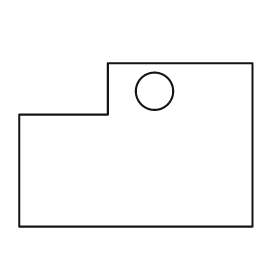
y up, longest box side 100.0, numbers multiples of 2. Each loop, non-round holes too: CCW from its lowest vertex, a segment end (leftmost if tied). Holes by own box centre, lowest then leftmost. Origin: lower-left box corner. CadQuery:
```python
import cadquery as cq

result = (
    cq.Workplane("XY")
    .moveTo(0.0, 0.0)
    .lineTo(100.0, 0.0)
    .lineTo(100.0, 70.0)
    .lineTo(38.0, 70.0)
    .lineTo(38.0, 48.0)
    .lineTo(0.0, 48.0)
    .close()
    .moveTo(58.0, 58.0)
    .circle(8.0)
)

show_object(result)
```